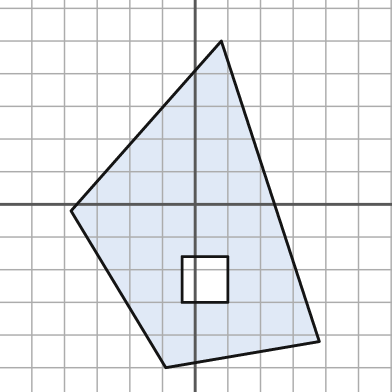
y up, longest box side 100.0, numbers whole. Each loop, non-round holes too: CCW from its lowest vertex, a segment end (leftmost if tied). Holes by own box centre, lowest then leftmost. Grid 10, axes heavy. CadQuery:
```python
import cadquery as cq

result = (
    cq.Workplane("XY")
    .moveTo(-9.0, -50.0)
    .lineTo(38.0, -42.0)
    .lineTo(8.0, 50.0)
    .lineTo(-38.0, -2.0)
    .close()
    .moveTo(-4.0, -30.0)
    .lineTo(10.0, -30.0)
    .lineTo(10.0, -16.0)
    .lineTo(-4.0, -16.0)
    .close()
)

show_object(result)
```